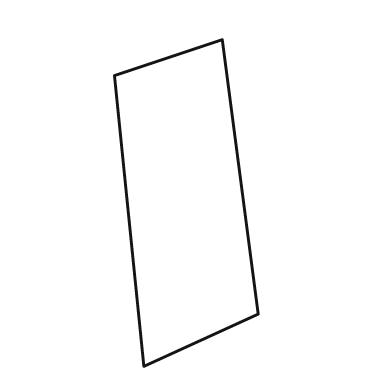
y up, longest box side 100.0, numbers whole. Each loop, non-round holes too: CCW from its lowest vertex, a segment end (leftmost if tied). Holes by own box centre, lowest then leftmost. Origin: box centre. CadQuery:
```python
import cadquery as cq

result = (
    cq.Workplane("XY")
    .moveTo(-13.0, -50.0)
    .lineTo(22.0, -34.0)
    .lineTo(11.0, 50.0)
    .lineTo(-22.0, 39.0)
    .close()
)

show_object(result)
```